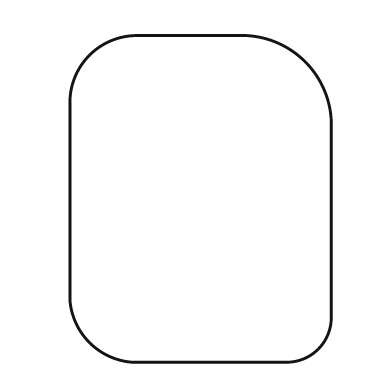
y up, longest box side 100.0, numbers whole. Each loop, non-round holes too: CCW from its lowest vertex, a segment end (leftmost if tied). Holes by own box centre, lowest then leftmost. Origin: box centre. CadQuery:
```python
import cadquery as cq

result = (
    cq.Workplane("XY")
    .moveTo(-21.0, -50.0)
    .lineTo(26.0, -50.0)
    .threePointArc((36.0, -46.0), (40.0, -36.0))
    .lineTo(40.0, 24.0)
    .threePointArc((32.0, 42.0), (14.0, 50.0))
    .lineTo(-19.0, 50.0)
    .threePointArc((-34.0, 44.0), (-40.0, 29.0))
    .lineTo(-40.0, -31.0)
    .threePointArc((-34.0, -44.0), (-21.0, -50.0))
    .close()
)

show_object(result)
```